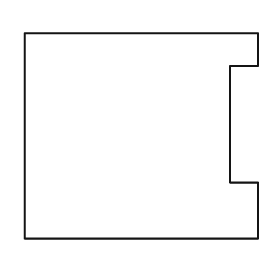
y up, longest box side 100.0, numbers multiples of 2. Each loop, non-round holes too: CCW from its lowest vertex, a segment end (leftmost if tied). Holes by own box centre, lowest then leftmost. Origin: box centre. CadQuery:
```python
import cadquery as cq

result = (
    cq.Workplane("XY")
    .moveTo(-50.0, -44.0)
    .lineTo(50.0, -44.0)
    .lineTo(50.0, -20.0)
    .lineTo(38.0, -20.0)
    .lineTo(38.0, 30.0)
    .lineTo(50.0, 30.0)
    .lineTo(50.0, 44.0)
    .lineTo(-50.0, 44.0)
    .close()
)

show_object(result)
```